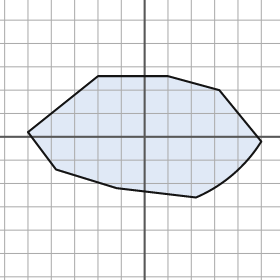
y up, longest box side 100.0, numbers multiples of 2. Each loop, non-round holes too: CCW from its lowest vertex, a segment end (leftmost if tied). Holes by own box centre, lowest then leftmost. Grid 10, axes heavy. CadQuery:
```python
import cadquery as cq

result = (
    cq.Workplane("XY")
    .moveTo(22.0, -26.0)
    .threePointArc((38.0, -16.0), (50.0, -2.0))
    .lineTo(32.0, 20.0)
    .lineTo(10.0, 26.0)
    .lineTo(-20.0, 26.0)
    .lineTo(-50.0, 2.0)
    .lineTo(-38.0, -14.0)
    .lineTo(-12.0, -22.0)
    .close()
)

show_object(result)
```